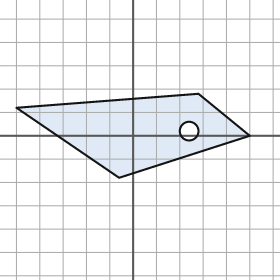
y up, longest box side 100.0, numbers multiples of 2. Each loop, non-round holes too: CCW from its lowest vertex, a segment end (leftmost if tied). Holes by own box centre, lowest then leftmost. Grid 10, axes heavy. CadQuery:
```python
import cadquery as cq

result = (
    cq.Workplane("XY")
    .moveTo(-6.0, -18.0)
    .lineTo(50.0, 0.0)
    .lineTo(28.0, 18.0)
    .lineTo(-50.0, 12.0)
    .close()
    .moveTo(24.0, 2.0)
    .circle(4.0)
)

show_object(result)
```